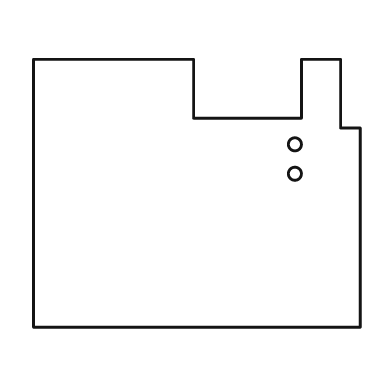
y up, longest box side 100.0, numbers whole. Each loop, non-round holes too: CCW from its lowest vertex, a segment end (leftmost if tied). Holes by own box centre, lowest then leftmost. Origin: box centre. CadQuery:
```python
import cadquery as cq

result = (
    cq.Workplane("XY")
    .moveTo(-50.0, -41.0)
    .lineTo(50.0, -41.0)
    .lineTo(50.0, 20.0)
    .lineTo(44.0, 20.0)
    .lineTo(44.0, 41.0)
    .lineTo(32.0, 41.0)
    .lineTo(32.0, 23.0)
    .lineTo(-1.0, 23.0)
    .lineTo(-1.0, 41.0)
    .lineTo(-50.0, 41.0)
    .close()
    .moveTo(30.0, 6.0)
    .circle(2.0)
    .moveTo(30.0, 15.0)
    .circle(2.0)
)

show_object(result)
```